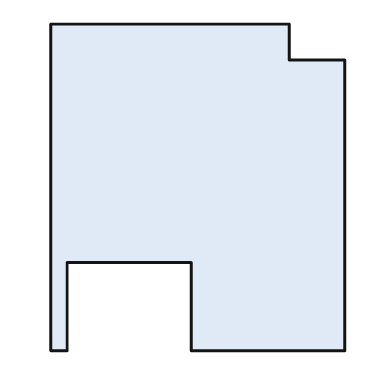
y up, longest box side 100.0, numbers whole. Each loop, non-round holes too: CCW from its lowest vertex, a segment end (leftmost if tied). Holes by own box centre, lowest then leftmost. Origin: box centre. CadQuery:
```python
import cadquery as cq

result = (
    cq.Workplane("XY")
    .moveTo(-45.0, -50.0)
    .lineTo(-40.0, -50.0)
    .lineTo(-40.0, -23.0)
    .lineTo(-2.0, -23.0)
    .lineTo(-2.0, -50.0)
    .lineTo(45.0, -50.0)
    .lineTo(45.0, 39.0)
    .lineTo(28.0, 39.0)
    .lineTo(28.0, 50.0)
    .lineTo(-45.0, 50.0)
    .close()
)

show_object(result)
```